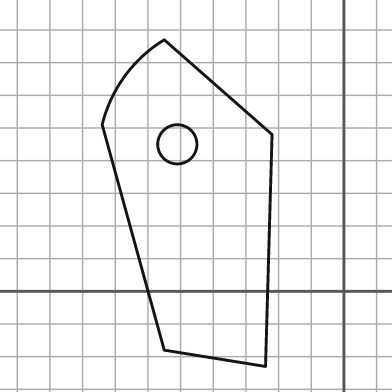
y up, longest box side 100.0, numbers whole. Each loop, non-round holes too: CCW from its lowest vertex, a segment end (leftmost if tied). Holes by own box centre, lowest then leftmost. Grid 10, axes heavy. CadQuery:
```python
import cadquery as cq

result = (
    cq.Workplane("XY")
    .moveTo(-24.0, -23.0)
    .lineTo(-22.0, 48.0)
    .lineTo(-55.0, 77.0)
    .threePointArc((-67.0, 66.0), (-74.0, 51.0))
    .lineTo(-55.0, -18.0)
    .close()
    .moveTo(-51.0, 45.0)
    .circle(6.0)
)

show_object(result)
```